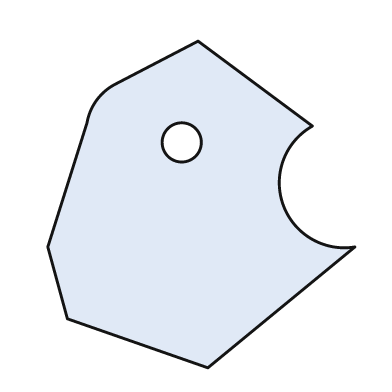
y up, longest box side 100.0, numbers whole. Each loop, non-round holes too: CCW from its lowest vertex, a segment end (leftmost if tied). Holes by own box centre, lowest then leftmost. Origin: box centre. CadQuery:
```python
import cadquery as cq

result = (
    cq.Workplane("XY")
    .moveTo(2.0, -50.0)
    .lineTo(47.0, -13.0)
    .threePointArc((25.0, 0.0), (34.0, 24.0))
    .lineTo(-1.0, 50.0)
    .lineTo(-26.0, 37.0)
    .threePointArc((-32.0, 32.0), (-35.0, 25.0))
    .lineTo(-47.0, -13.0)
    .lineTo(-41.0, -35.0)
    .close()
    .moveTo(-6.0, 19.0)
    .circle(6.0)
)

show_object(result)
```